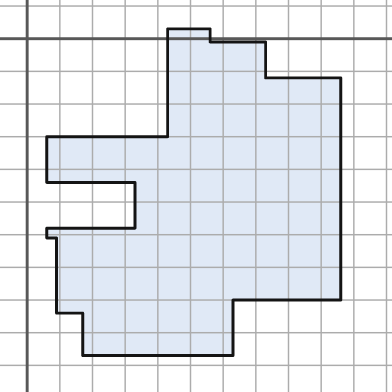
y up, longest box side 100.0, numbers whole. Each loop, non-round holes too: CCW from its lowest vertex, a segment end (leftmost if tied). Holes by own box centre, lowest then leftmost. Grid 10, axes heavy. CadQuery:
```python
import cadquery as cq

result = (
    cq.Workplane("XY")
    .moveTo(17.0, -97.0)
    .lineTo(63.0, -97.0)
    .lineTo(63.0, -80.0)
    .lineTo(96.0, -80.0)
    .lineTo(96.0, -12.0)
    .lineTo(73.0, -12.0)
    .lineTo(73.0, -1.0)
    .lineTo(56.0, -1.0)
    .lineTo(56.0, 3.0)
    .lineTo(43.0, 3.0)
    .lineTo(43.0, -30.0)
    .lineTo(6.0, -30.0)
    .lineTo(6.0, -44.0)
    .lineTo(33.0, -44.0)
    .lineTo(33.0, -58.0)
    .lineTo(6.0, -58.0)
    .lineTo(6.0, -61.0)
    .lineTo(9.0, -61.0)
    .lineTo(9.0, -84.0)
    .lineTo(17.0, -84.0)
    .close()
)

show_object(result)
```